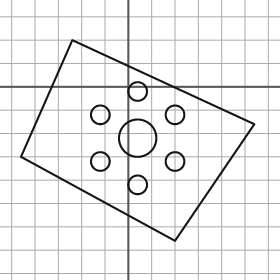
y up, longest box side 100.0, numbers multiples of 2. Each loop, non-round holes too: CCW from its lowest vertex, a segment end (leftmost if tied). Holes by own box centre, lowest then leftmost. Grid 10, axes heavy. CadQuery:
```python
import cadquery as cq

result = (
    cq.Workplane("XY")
    .moveTo(20.0, -66.0)
    .lineTo(54.0, -16.0)
    .lineTo(-24.0, 20.0)
    .lineTo(-46.0, -30.0)
    .close()
    .moveTo(4.0, -42.0)
    .circle(4.0)
    .moveTo(-12.0, -32.0)
    .circle(4.0)
    .moveTo(20.0, -32.0)
    .circle(4.0)
    .moveTo(4.0, -22.0)
    .circle(8.0)
    .moveTo(-12.0, -12.0)
    .circle(4.0)
    .moveTo(20.0, -12.0)
    .circle(4.0)
    .moveTo(4.0, -2.0)
    .circle(4.0)
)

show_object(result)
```